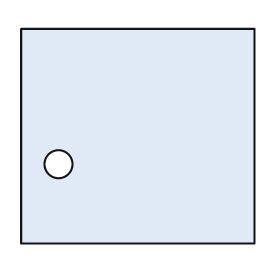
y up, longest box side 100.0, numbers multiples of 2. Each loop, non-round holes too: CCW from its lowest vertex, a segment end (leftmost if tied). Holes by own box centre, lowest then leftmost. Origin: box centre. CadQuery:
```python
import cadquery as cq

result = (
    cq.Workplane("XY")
    .moveTo(-50.0, -46.0)
    .lineTo(50.0, -46.0)
    .lineTo(50.0, 46.0)
    .lineTo(-50.0, 46.0)
    .close()
    .moveTo(-34.0, -12.0)
    .circle(6.0)
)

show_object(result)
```